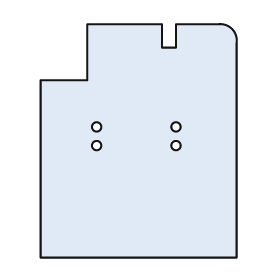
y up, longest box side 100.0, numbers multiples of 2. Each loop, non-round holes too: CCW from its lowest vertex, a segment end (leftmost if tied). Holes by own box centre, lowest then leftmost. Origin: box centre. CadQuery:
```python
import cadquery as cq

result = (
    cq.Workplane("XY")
    .moveTo(-42.0, -50.0)
    .lineTo(42.0, -50.0)
    .lineTo(42.0, 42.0)
    .threePointArc((40.0, 48.0), (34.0, 50.0))
    .lineTo(16.0, 50.0)
    .lineTo(16.0, 40.0)
    .lineTo(10.0, 40.0)
    .lineTo(10.0, 50.0)
    .lineTo(-22.0, 50.0)
    .lineTo(-22.0, 26.0)
    .lineTo(-42.0, 26.0)
    .close()
    .moveTo(-18.0, -2.0)
    .circle(2.0)
    .moveTo(16.0, -2.0)
    .circle(2.0)
    .moveTo(-18.0, 6.0)
    .circle(2.0)
    .moveTo(16.0, 6.0)
    .circle(2.0)
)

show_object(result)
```